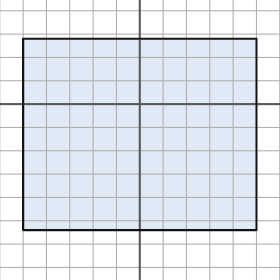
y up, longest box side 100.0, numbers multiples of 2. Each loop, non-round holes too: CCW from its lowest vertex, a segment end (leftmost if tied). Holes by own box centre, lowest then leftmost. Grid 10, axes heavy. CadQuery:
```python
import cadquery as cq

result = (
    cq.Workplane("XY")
    .moveTo(-50.0, -54.0)
    .lineTo(50.0, -54.0)
    .lineTo(50.0, 28.0)
    .lineTo(-50.0, 28.0)
    .close()
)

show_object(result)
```